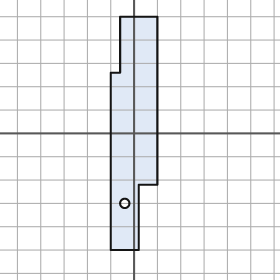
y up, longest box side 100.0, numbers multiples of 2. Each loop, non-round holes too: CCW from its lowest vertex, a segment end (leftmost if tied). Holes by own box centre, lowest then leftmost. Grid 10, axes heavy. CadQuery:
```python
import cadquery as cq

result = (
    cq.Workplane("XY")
    .moveTo(-10.0, -50.0)
    .lineTo(2.0, -50.0)
    .lineTo(2.0, -22.0)
    .lineTo(10.0, -22.0)
    .lineTo(10.0, 50.0)
    .lineTo(-6.0, 50.0)
    .lineTo(-6.0, 26.0)
    .lineTo(-10.0, 26.0)
    .close()
    .moveTo(-4.0, -30.0)
    .circle(2.0)
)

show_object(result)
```